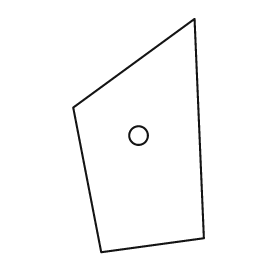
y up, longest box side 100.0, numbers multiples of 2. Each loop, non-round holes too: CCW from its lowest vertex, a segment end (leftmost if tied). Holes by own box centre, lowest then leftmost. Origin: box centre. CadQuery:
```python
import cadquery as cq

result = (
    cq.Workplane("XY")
    .moveTo(-16.0, -50.0)
    .lineTo(28.0, -44.0)
    .lineTo(24.0, 50.0)
    .lineTo(-28.0, 12.0)
    .close()
    .moveTo(0.0, 0.0)
    .circle(4.0)
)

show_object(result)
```